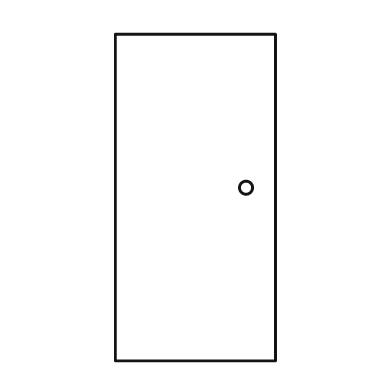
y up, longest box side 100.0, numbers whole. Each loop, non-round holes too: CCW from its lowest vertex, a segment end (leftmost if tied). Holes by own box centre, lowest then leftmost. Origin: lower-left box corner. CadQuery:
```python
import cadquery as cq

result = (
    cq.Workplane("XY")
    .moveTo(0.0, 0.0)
    .lineTo(49.0, 0.0)
    .lineTo(49.0, 100.0)
    .lineTo(0.0, 100.0)
    .close()
    .moveTo(40.0, 53.0)
    .circle(2.0)
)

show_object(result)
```